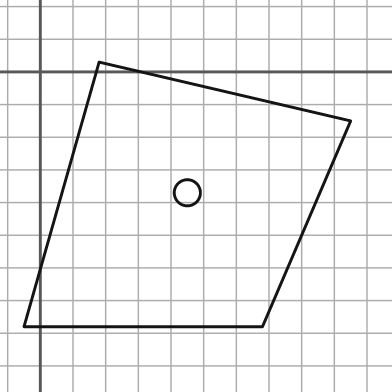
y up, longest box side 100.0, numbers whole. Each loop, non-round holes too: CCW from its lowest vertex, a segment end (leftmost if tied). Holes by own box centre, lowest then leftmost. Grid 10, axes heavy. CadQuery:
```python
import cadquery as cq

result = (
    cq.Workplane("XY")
    .moveTo(-5.0, -78.0)
    .lineTo(68.0, -78.0)
    .lineTo(95.0, -15.0)
    .lineTo(18.0, 3.0)
    .close()
    .moveTo(45.0, -37.0)
    .circle(4.0)
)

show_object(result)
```